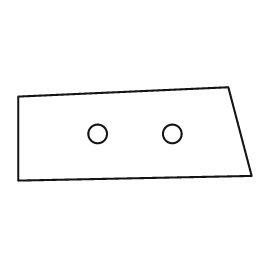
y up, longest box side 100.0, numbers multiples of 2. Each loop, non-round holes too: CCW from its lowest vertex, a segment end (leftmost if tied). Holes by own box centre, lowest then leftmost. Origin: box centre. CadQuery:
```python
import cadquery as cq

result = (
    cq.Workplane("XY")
    .moveTo(-50.0, -20.0)
    .lineTo(50.0, -18.0)
    .lineTo(40.0, 20.0)
    .lineTo(-50.0, 16.0)
    .close()
    .moveTo(-16.0, 0.0)
    .circle(4.0)
    .moveTo(16.0, 0.0)
    .circle(4.0)
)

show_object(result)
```